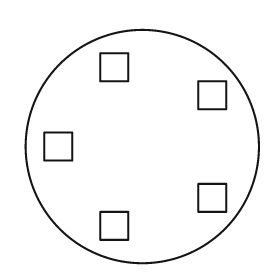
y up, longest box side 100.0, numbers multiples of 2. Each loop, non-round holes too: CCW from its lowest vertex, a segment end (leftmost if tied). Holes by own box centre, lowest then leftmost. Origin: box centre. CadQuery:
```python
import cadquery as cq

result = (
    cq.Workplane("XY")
    .moveTo(0.0, 0.0)
    .circle(50.0)
    .moveTo(-18.0, -40.0)
    .lineTo(-6.0, -40.0)
    .lineTo(-6.0, -28.0)
    .lineTo(-18.0, -28.0)
    .close()
    .moveTo(24.0, -28.0)
    .lineTo(36.0, -28.0)
    .lineTo(36.0, -16.0)
    .lineTo(24.0, -16.0)
    .close()
    .moveTo(-42.0, -6.0)
    .lineTo(-30.0, -6.0)
    .lineTo(-30.0, 6.0)
    .lineTo(-42.0, 6.0)
    .close()
    .moveTo(24.0, 16.0)
    .lineTo(36.0, 16.0)
    .lineTo(36.0, 28.0)
    .lineTo(24.0, 28.0)
    .close()
    .moveTo(-18.0, 28.0)
    .lineTo(-6.0, 28.0)
    .lineTo(-6.0, 40.0)
    .lineTo(-18.0, 40.0)
    .close()
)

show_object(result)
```